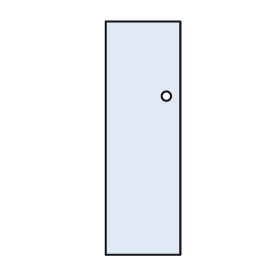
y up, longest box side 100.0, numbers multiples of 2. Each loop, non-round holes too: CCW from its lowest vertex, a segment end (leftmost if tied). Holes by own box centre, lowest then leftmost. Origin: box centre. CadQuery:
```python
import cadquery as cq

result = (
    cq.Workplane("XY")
    .moveTo(-16.0, -50.0)
    .lineTo(16.0, -50.0)
    .lineTo(16.0, 50.0)
    .lineTo(-16.0, 50.0)
    .close()
    .moveTo(10.0, 18.0)
    .circle(2.0)
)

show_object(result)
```